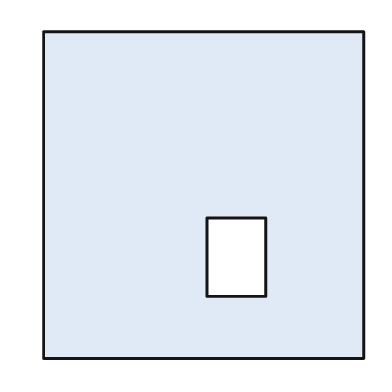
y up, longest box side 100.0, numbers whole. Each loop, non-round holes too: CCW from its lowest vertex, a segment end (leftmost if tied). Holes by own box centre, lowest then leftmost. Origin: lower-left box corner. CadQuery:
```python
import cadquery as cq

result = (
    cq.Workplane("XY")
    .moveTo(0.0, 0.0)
    .lineTo(98.0, 0.0)
    .lineTo(98.0, 100.0)
    .lineTo(0.0, 100.0)
    .close()
    .moveTo(50.0, 19.0)
    .lineTo(68.0, 19.0)
    .lineTo(68.0, 43.0)
    .lineTo(50.0, 43.0)
    .close()
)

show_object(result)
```